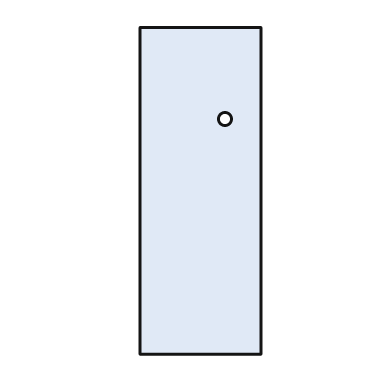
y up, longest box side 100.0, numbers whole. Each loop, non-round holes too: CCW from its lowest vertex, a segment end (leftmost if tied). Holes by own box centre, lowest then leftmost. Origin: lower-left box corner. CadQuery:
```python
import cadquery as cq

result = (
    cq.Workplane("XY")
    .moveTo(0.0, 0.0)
    .lineTo(37.0, 0.0)
    .lineTo(37.0, 100.0)
    .lineTo(0.0, 100.0)
    .close()
    .moveTo(26.0, 72.0)
    .circle(2.0)
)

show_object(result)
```